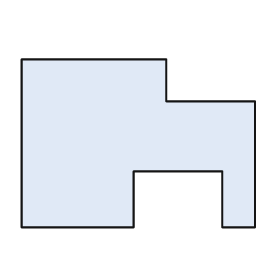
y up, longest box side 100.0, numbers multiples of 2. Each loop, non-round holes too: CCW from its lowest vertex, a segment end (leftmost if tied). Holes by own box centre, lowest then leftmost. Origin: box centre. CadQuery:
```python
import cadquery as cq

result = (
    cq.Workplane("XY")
    .moveTo(-50.0, -36.0)
    .lineTo(-2.0, -36.0)
    .lineTo(-2.0, -12.0)
    .lineTo(36.0, -12.0)
    .lineTo(36.0, -36.0)
    .lineTo(50.0, -36.0)
    .lineTo(50.0, 18.0)
    .lineTo(12.0, 18.0)
    .lineTo(12.0, 36.0)
    .lineTo(-50.0, 36.0)
    .close()
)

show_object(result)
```